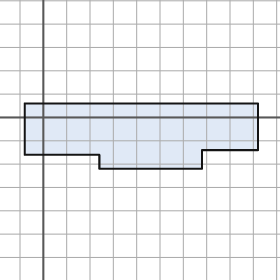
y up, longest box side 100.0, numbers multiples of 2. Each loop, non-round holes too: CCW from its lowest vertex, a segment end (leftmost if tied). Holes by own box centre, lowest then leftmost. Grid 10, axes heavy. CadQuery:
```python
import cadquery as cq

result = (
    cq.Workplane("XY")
    .moveTo(24.0, -22.0)
    .lineTo(68.0, -22.0)
    .lineTo(68.0, -14.0)
    .lineTo(92.0, -14.0)
    .lineTo(92.0, 6.0)
    .lineTo(-8.0, 6.0)
    .lineTo(-8.0, -16.0)
    .lineTo(24.0, -16.0)
    .close()
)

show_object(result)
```